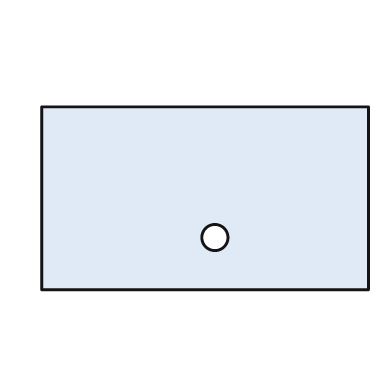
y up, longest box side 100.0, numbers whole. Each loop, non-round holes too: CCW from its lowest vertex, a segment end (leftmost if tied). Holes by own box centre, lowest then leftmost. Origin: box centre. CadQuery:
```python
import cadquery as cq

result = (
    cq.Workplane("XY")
    .moveTo(-50.0, -28.0)
    .lineTo(50.0, -28.0)
    .lineTo(50.0, 28.0)
    .lineTo(-50.0, 28.0)
    .close()
    .moveTo(3.0, -12.0)
    .circle(4.0)
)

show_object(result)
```